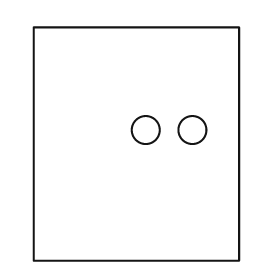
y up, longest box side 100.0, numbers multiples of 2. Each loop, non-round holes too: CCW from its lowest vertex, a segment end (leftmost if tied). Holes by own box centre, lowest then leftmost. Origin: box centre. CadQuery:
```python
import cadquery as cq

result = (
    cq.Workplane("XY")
    .moveTo(-44.0, -50.0)
    .lineTo(44.0, -50.0)
    .lineTo(44.0, 50.0)
    .lineTo(-44.0, 50.0)
    .close()
    .moveTo(4.0, 6.0)
    .circle(6.0)
    .moveTo(24.0, 6.0)
    .circle(6.0)
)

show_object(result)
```